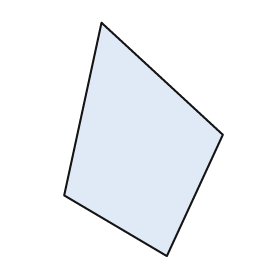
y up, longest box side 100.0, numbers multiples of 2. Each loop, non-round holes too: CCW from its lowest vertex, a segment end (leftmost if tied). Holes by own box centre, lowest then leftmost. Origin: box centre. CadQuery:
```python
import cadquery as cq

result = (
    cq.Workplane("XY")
    .moveTo(10.0, -50.0)
    .lineTo(34.0, 2.0)
    .lineTo(-18.0, 50.0)
    .lineTo(-34.0, -24.0)
    .close()
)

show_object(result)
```